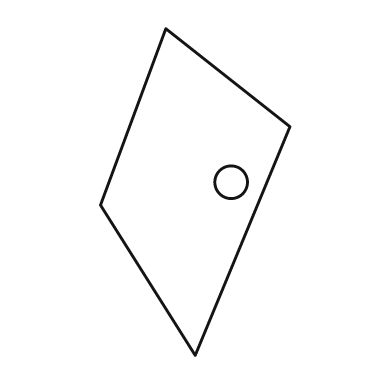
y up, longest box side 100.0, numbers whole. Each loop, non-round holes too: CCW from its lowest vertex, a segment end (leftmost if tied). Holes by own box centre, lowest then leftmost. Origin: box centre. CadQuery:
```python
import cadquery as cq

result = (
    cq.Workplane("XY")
    .moveTo(0.0, -50.0)
    .lineTo(29.0, 20.0)
    .lineTo(-9.0, 50.0)
    .lineTo(-29.0, -4.0)
    .close()
    .moveTo(11.0, 3.0)
    .circle(5.0)
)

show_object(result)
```